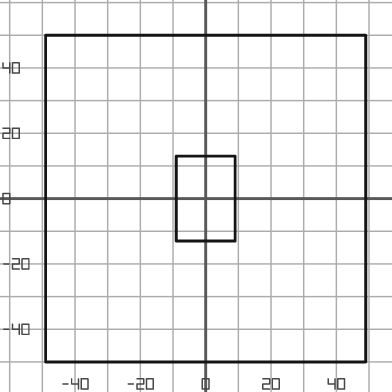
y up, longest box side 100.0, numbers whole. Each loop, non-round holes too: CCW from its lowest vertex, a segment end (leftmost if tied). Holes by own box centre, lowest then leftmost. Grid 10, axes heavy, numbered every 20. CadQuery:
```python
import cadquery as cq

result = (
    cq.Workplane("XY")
    .moveTo(-49.0, -50.0)
    .lineTo(49.0, -50.0)
    .lineTo(49.0, 50.0)
    .lineTo(-49.0, 50.0)
    .close()
    .moveTo(-9.0, -13.0)
    .lineTo(9.0, -13.0)
    .lineTo(9.0, 13.0)
    .lineTo(-9.0, 13.0)
    .close()
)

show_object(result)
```